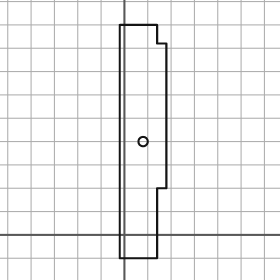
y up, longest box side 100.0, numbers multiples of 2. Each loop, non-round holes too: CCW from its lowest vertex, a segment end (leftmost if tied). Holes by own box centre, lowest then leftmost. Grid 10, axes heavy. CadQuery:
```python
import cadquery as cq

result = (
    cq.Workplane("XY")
    .moveTo(-2.0, -10.0)
    .lineTo(14.0, -10.0)
    .lineTo(14.0, 20.0)
    .lineTo(18.0, 20.0)
    .lineTo(18.0, 82.0)
    .lineTo(14.0, 82.0)
    .lineTo(14.0, 90.0)
    .lineTo(-2.0, 90.0)
    .close()
    .moveTo(8.0, 40.0)
    .circle(2.0)
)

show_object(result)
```